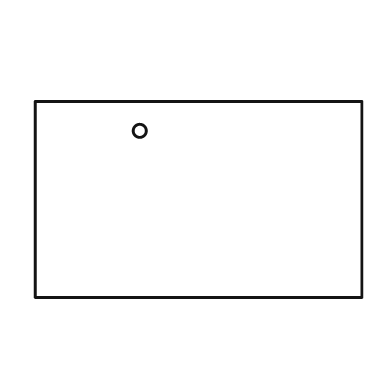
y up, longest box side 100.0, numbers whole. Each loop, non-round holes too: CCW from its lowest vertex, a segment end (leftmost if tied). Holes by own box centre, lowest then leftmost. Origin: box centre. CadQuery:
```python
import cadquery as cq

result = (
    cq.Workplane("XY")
    .moveTo(-50.0, -30.0)
    .lineTo(50.0, -30.0)
    .lineTo(50.0, 30.0)
    .lineTo(-50.0, 30.0)
    .close()
    .moveTo(-18.0, 21.0)
    .circle(2.0)
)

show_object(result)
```